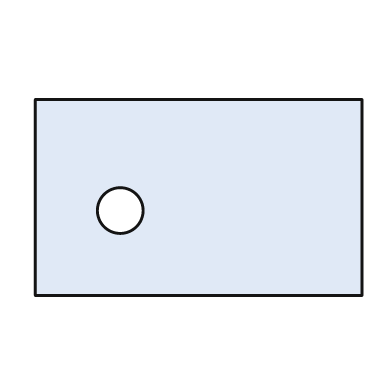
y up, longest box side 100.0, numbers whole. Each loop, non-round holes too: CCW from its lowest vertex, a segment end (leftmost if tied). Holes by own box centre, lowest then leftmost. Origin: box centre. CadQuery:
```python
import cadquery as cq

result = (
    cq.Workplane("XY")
    .moveTo(-50.0, -30.0)
    .lineTo(50.0, -30.0)
    .lineTo(50.0, 30.0)
    .lineTo(-50.0, 30.0)
    .close()
    .moveTo(-24.0, -4.0)
    .circle(7.0)
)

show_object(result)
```